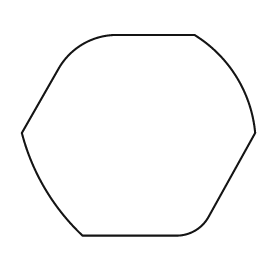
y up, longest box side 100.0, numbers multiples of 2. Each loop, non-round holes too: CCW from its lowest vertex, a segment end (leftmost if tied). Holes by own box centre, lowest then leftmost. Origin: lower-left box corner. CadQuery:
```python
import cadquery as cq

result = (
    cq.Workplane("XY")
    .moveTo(26.0, 0.0)
    .lineTo(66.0, 0.0)
    .threePointArc((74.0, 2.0), (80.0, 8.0))
    .lineTo(100.0, 44.0)
    .threePointArc((92.0, 68.0), (74.0, 86.0))
    .lineTo(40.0, 86.0)
    .threePointArc((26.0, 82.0), (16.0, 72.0))
    .lineTo(0.0, 44.0)
    .threePointArc((10.0, 20.0), (26.0, 0.0))
    .close()
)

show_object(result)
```